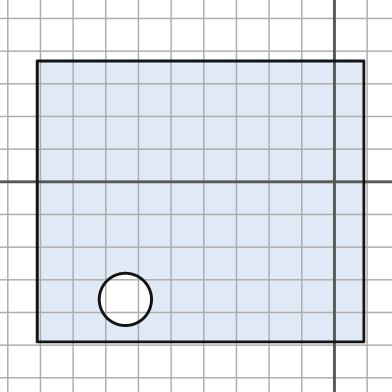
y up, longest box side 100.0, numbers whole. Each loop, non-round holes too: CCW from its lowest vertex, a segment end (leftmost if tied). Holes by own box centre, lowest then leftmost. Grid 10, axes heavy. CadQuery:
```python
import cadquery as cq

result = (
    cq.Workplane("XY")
    .moveTo(-91.0, -49.0)
    .lineTo(9.0, -49.0)
    .lineTo(9.0, 37.0)
    .lineTo(-91.0, 37.0)
    .close()
    .moveTo(-64.0, -36.0)
    .circle(8.0)
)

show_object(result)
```